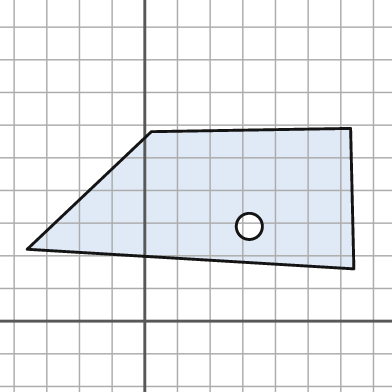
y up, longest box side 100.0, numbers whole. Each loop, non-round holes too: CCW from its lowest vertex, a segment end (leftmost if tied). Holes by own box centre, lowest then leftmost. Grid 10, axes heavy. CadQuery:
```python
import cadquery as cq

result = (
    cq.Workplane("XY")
    .moveTo(64.0, 16.0)
    .lineTo(63.0, 59.0)
    .lineTo(2.0, 58.0)
    .lineTo(-36.0, 22.0)
    .close()
    .moveTo(32.0, 29.0)
    .circle(4.0)
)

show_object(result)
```